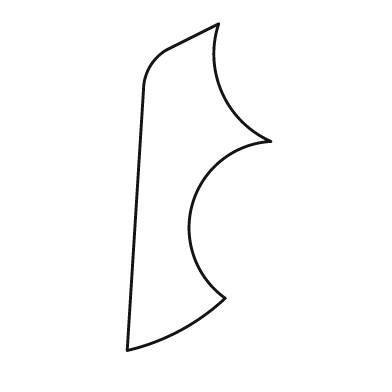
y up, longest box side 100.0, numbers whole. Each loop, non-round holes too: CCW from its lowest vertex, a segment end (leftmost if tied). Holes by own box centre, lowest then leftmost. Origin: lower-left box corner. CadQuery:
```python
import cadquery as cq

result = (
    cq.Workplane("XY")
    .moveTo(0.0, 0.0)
    .threePointArc((16.0, 6.0), (30.0, 16.0))
    .threePointArc((20.0, 45.0), (44.0, 64.0))
    .threePointArc((29.0, 79.0), (28.0, 100.0))
    .lineTo(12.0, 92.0)
    .threePointArc((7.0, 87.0), (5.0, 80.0))
    .close()
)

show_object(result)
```